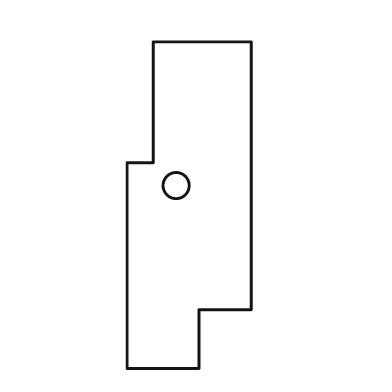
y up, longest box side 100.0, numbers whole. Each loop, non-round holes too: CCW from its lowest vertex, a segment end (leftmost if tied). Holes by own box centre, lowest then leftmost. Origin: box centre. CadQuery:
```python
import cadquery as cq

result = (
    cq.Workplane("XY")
    .moveTo(-19.0, -50.0)
    .lineTo(3.0, -50.0)
    .lineTo(3.0, -32.0)
    .lineTo(19.0, -32.0)
    .lineTo(19.0, 50.0)
    .lineTo(-11.0, 50.0)
    .lineTo(-11.0, 13.0)
    .lineTo(-19.0, 13.0)
    .close()
    .moveTo(-4.0, 6.0)
    .circle(4.0)
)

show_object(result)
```